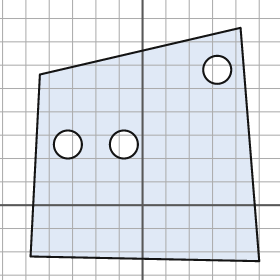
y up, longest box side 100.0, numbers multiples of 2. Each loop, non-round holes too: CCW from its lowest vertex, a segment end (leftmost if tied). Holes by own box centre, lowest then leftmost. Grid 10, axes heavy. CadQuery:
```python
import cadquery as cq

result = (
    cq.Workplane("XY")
    .moveTo(50.0, -24.0)
    .lineTo(42.0, 76.0)
    .lineTo(-44.0, 56.0)
    .lineTo(-48.0, -22.0)
    .close()
    .moveTo(-32.0, 26.0)
    .circle(6.0)
    .moveTo(-8.0, 26.0)
    .circle(6.0)
    .moveTo(32.0, 58.0)
    .circle(6.0)
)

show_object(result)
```